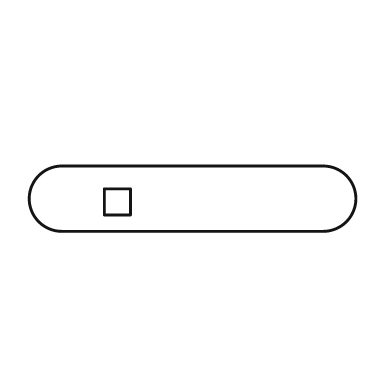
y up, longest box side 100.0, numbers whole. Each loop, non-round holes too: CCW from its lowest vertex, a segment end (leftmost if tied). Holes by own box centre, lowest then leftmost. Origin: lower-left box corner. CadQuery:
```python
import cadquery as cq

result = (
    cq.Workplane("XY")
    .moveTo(10.0, 0.0)
    .lineTo(90.0, 0.0)
    .threePointArc((100.0, 10.0), (90.0, 20.0))
    .lineTo(10.0, 20.0)
    .threePointArc((0.0, 10.0), (10.0, 0.0))
    .close()
    .moveTo(23.0, 5.0)
    .lineTo(31.0, 5.0)
    .lineTo(31.0, 13.0)
    .lineTo(23.0, 13.0)
    .close()
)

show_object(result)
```